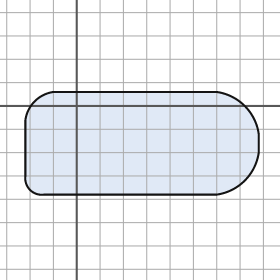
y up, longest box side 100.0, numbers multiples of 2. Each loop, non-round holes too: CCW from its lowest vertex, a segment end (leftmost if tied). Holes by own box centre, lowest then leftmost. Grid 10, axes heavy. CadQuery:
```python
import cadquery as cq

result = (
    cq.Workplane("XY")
    .moveTo(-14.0, -38.0)
    .lineTo(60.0, -38.0)
    .threePointArc((72.0, -32.0), (78.0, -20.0))
    .lineTo(78.0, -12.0)
    .threePointArc((72.0, 0.0), (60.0, 6.0))
    .lineTo(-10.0, 6.0)
    .threePointArc((-18.0, 2.0), (-22.0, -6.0))
    .lineTo(-22.0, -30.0)
    .threePointArc((-20.0, -36.0), (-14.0, -38.0))
    .close()
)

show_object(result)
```